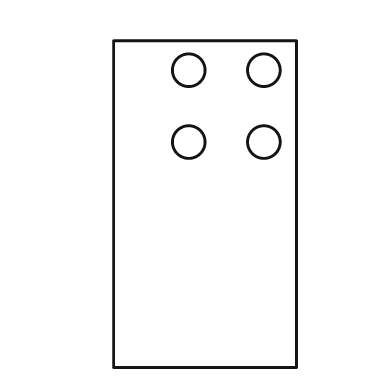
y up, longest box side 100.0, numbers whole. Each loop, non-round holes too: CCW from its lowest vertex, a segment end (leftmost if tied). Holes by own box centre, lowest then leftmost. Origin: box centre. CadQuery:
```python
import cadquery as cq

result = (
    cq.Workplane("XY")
    .moveTo(-28.0, -50.0)
    .lineTo(28.0, -50.0)
    .lineTo(28.0, 50.0)
    .lineTo(-28.0, 50.0)
    .close()
    .moveTo(-5.0, 19.0)
    .circle(5.0)
    .moveTo(18.0, 19.0)
    .circle(5.0)
    .moveTo(-5.0, 41.0)
    .circle(5.0)
    .moveTo(18.0, 41.0)
    .circle(5.0)
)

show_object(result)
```